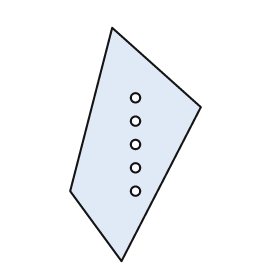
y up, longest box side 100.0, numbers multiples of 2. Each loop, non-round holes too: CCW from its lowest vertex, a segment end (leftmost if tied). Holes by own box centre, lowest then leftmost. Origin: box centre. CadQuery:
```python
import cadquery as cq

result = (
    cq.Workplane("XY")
    .moveTo(-6.0, -50.0)
    .lineTo(28.0, 16.0)
    .lineTo(-10.0, 50.0)
    .lineTo(-28.0, -20.0)
    .close()
    .moveTo(0.0, -20.0)
    .circle(2.0)
    .moveTo(0.0, -10.0)
    .circle(2.0)
    .moveTo(0.0, 0.0)
    .circle(2.0)
    .moveTo(0.0, 10.0)
    .circle(2.0)
    .moveTo(0.0, 20.0)
    .circle(2.0)
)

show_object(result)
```